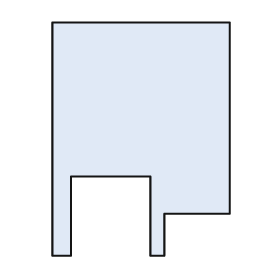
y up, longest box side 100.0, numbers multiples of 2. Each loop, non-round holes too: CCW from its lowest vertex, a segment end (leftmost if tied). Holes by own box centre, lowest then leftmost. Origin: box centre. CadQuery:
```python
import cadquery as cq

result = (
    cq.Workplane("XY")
    .moveTo(-38.0, -50.0)
    .lineTo(-30.0, -50.0)
    .lineTo(-30.0, -16.0)
    .lineTo(4.0, -16.0)
    .lineTo(4.0, -50.0)
    .lineTo(10.0, -50.0)
    .lineTo(10.0, -32.0)
    .lineTo(38.0, -32.0)
    .lineTo(38.0, 50.0)
    .lineTo(-38.0, 50.0)
    .close()
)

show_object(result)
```